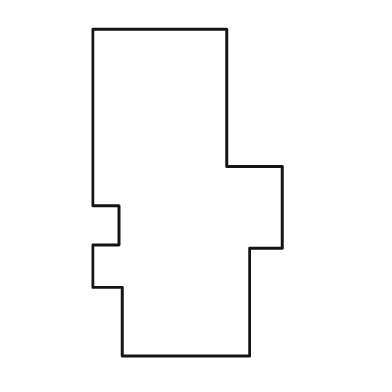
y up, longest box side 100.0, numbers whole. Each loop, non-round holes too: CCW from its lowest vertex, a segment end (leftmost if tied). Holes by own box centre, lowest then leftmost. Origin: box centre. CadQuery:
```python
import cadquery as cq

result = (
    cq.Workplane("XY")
    .moveTo(-20.0, -50.0)
    .lineTo(19.0, -50.0)
    .lineTo(19.0, -17.0)
    .lineTo(29.0, -17.0)
    .lineTo(29.0, 8.0)
    .lineTo(12.0, 8.0)
    .lineTo(12.0, 50.0)
    .lineTo(-29.0, 50.0)
    .lineTo(-29.0, -4.0)
    .lineTo(-21.0, -4.0)
    .lineTo(-21.0, -16.0)
    .lineTo(-29.0, -16.0)
    .lineTo(-29.0, -29.0)
    .lineTo(-20.0, -29.0)
    .close()
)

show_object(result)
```